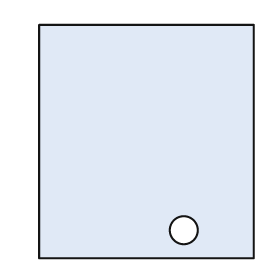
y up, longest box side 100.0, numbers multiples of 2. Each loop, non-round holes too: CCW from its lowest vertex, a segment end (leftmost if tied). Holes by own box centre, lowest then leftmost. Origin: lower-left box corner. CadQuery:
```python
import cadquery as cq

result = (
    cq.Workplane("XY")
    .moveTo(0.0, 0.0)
    .lineTo(92.0, 0.0)
    .lineTo(92.0, 100.0)
    .lineTo(0.0, 100.0)
    .close()
    .moveTo(62.0, 12.0)
    .circle(6.0)
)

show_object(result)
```